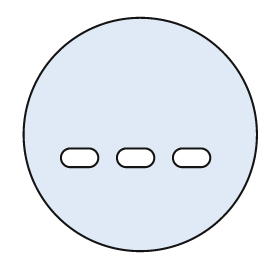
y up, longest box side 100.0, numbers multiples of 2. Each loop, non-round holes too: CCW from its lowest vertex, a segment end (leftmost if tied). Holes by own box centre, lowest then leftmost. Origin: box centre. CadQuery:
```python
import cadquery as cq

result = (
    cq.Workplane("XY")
    .moveTo(0.0, 0.0)
    .circle(50.0)
    .moveTo(-30.0, -14.0)
    .lineTo(-22.0, -14.0)
    .threePointArc((-18.0, -10.0), (-22.0, -6.0))
    .lineTo(-30.0, -6.0)
    .threePointArc((-34.0, -10.0), (-30.0, -14.0))
    .close()
    .moveTo(-6.0, -14.0)
    .lineTo(2.0, -14.0)
    .threePointArc((6.0, -10.0), (2.0, -6.0))
    .lineTo(-6.0, -6.0)
    .threePointArc((-10.0, -10.0), (-6.0, -14.0))
    .close()
    .moveTo(18.0, -14.0)
    .lineTo(26.0, -14.0)
    .threePointArc((30.0, -10.0), (26.0, -6.0))
    .lineTo(18.0, -6.0)
    .threePointArc((14.0, -10.0), (18.0, -14.0))
    .close()
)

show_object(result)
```